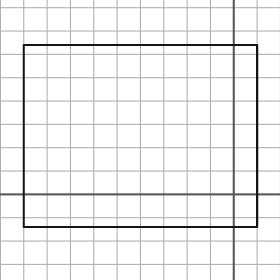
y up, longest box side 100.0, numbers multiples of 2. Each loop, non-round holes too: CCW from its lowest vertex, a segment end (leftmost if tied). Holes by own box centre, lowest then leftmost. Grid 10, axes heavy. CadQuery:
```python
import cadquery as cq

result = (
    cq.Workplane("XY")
    .moveTo(-90.0, -14.0)
    .lineTo(10.0, -14.0)
    .lineTo(10.0, 64.0)
    .lineTo(-90.0, 64.0)
    .close()
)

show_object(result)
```